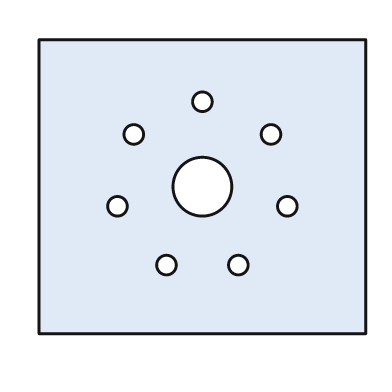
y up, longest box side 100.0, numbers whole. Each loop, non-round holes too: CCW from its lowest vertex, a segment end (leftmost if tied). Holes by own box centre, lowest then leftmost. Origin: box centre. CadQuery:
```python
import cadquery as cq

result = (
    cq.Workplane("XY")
    .moveTo(-50.0, -45.0)
    .lineTo(50.0, -45.0)
    .lineTo(50.0, 45.0)
    .lineTo(-50.0, 45.0)
    .close()
    .moveTo(-11.0, -24.0)
    .circle(3.0)
    .moveTo(11.0, -24.0)
    .circle(3.0)
    .moveTo(-26.0, -6.0)
    .circle(3.0)
    .moveTo(26.0, -6.0)
    .circle(3.0)
    .moveTo(0.0, 0.0)
    .circle(9.0)
    .moveTo(-21.0, 16.0)
    .circle(3.0)
    .moveTo(21.0, 16.0)
    .circle(3.0)
    .moveTo(0.0, 26.0)
    .circle(3.0)
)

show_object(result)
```